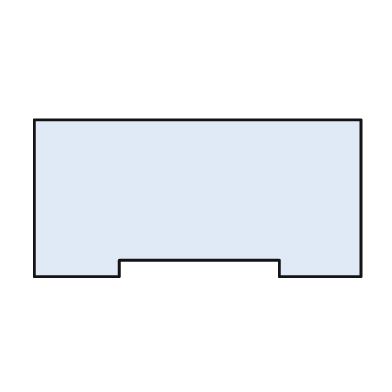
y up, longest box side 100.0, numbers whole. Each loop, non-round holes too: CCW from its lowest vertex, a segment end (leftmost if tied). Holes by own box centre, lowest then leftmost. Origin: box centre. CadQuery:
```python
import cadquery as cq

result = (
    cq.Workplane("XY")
    .moveTo(-50.0, -24.0)
    .lineTo(-24.0, -24.0)
    .lineTo(-24.0, -19.0)
    .lineTo(25.0, -19.0)
    .lineTo(25.0, -24.0)
    .lineTo(50.0, -24.0)
    .lineTo(50.0, 24.0)
    .lineTo(-50.0, 24.0)
    .close()
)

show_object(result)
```